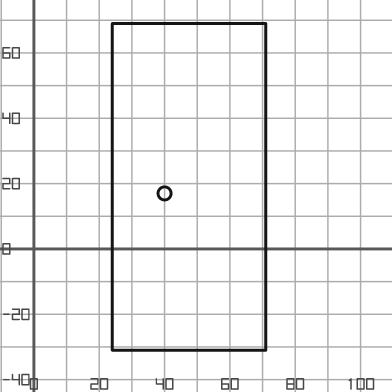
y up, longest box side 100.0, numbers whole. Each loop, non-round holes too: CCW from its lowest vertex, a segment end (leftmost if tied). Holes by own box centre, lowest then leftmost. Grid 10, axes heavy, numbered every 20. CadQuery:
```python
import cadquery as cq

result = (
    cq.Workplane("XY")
    .moveTo(24.0, -31.0)
    .lineTo(71.0, -31.0)
    .lineTo(71.0, 69.0)
    .lineTo(24.0, 69.0)
    .close()
    .moveTo(40.0, 17.0)
    .circle(2.0)
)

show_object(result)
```